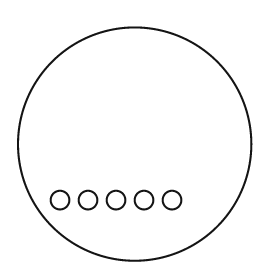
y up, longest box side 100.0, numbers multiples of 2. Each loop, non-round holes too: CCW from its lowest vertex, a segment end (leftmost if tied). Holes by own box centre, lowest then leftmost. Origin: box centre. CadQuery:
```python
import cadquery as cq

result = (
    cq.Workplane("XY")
    .moveTo(0.0, 0.0)
    .circle(50.0)
    .moveTo(-32.0, -24.0)
    .circle(4.0)
    .moveTo(-20.0, -24.0)
    .circle(4.0)
    .moveTo(-8.0, -24.0)
    .circle(4.0)
    .moveTo(4.0, -24.0)
    .circle(4.0)
    .moveTo(16.0, -24.0)
    .circle(4.0)
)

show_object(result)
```